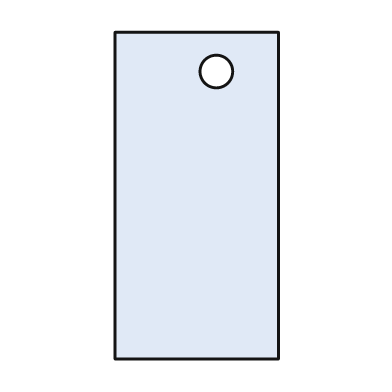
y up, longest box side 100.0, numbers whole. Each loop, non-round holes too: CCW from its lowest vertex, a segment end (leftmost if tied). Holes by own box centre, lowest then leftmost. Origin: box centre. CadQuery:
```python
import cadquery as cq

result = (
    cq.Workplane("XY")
    .moveTo(-25.0, -50.0)
    .lineTo(25.0, -50.0)
    .lineTo(25.0, 50.0)
    .lineTo(-25.0, 50.0)
    .close()
    .moveTo(6.0, 38.0)
    .circle(5.0)
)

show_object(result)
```